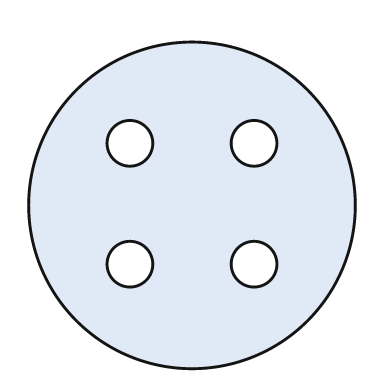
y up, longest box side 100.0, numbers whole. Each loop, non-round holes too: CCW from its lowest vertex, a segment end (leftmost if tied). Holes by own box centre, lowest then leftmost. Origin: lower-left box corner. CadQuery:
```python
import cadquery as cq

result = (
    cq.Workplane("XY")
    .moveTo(50.0, 50.0)
    .circle(50.0)
    .moveTo(31.0, 32.0)
    .circle(7.0)
    .moveTo(69.0, 32.0)
    .circle(7.0)
    .moveTo(31.0, 69.0)
    .circle(7.0)
    .moveTo(69.0, 69.0)
    .circle(7.0)
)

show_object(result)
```